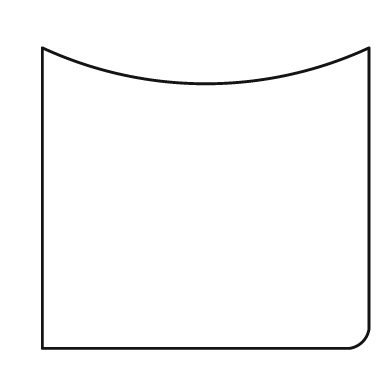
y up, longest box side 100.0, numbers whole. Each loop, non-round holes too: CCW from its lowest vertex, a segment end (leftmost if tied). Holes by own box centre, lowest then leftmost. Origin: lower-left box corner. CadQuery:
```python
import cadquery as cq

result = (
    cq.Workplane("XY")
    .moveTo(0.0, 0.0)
    .lineTo(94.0, 0.0)
    .threePointArc((98.0, 2.0), (100.0, 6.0))
    .lineTo(100.0, 92.0)
    .threePointArc((50.0, 81.0), (0.0, 92.0))
    .close()
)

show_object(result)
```